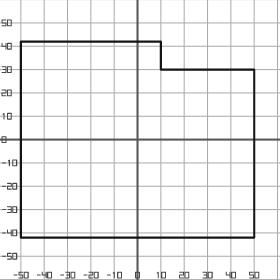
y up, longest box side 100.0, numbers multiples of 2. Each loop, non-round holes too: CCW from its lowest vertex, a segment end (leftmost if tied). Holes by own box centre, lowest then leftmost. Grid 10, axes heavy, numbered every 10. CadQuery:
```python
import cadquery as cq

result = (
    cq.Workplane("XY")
    .moveTo(-50.0, -42.0)
    .lineTo(50.0, -42.0)
    .lineTo(50.0, 30.0)
    .lineTo(10.0, 30.0)
    .lineTo(10.0, 42.0)
    .lineTo(-50.0, 42.0)
    .close()
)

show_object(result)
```